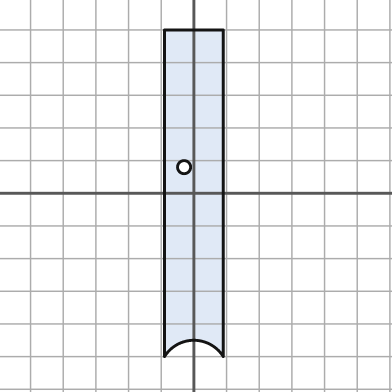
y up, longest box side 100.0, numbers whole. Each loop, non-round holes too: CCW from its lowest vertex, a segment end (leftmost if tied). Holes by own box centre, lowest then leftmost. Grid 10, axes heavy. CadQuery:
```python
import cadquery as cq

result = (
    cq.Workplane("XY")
    .moveTo(-9.0, -50.0)
    .threePointArc((0.0, -45.0), (9.0, -50.0))
    .lineTo(9.0, 50.0)
    .lineTo(-9.0, 50.0)
    .close()
    .moveTo(-3.0, 8.0)
    .circle(2.0)
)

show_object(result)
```